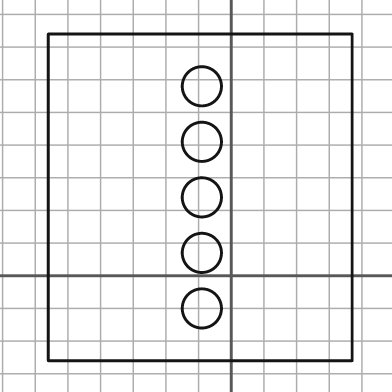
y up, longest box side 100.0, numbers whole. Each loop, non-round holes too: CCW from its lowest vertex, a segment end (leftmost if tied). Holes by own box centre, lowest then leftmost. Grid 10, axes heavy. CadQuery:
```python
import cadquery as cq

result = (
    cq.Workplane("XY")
    .moveTo(-56.0, -26.0)
    .lineTo(37.0, -26.0)
    .lineTo(37.0, 74.0)
    .lineTo(-56.0, 74.0)
    .close()
    .moveTo(-9.0, -10.0)
    .circle(6.0)
    .moveTo(-9.0, 7.0)
    .circle(6.0)
    .moveTo(-9.0, 24.0)
    .circle(6.0)
    .moveTo(-9.0, 41.0)
    .circle(6.0)
    .moveTo(-9.0, 58.0)
    .circle(6.0)
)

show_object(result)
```